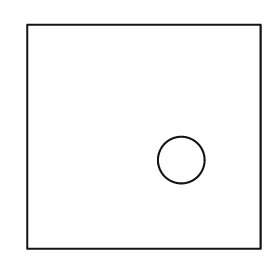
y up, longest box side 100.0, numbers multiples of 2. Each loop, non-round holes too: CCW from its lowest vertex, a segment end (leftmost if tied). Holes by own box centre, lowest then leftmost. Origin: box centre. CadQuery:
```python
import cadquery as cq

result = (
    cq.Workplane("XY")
    .moveTo(-50.0, -48.0)
    .lineTo(50.0, -48.0)
    .lineTo(50.0, 48.0)
    .lineTo(-50.0, 48.0)
    .close()
    .moveTo(16.0, -10.0)
    .circle(10.0)
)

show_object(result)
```